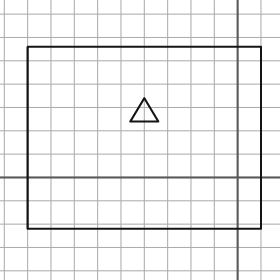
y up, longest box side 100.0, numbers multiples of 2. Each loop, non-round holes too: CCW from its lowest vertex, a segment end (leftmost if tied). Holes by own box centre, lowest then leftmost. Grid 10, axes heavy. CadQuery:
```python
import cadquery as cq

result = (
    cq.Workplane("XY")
    .moveTo(-90.0, -22.0)
    .lineTo(10.0, -22.0)
    .lineTo(10.0, 56.0)
    .lineTo(-90.0, 56.0)
    .close()
    .moveTo(-46.0, 24.0)
    .lineTo(-34.0, 24.0)
    .lineTo(-40.0, 34.0)
    .close()
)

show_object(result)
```